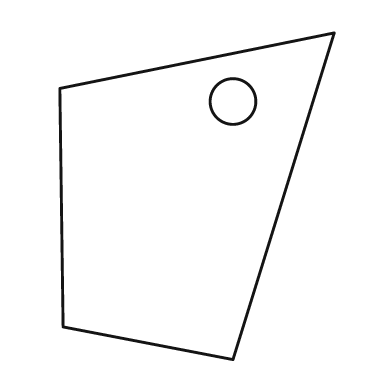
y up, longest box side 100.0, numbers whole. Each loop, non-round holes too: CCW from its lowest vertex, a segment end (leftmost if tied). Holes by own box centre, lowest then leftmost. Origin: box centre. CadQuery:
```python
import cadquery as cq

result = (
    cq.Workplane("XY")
    .moveTo(11.0, -50.0)
    .lineTo(42.0, 50.0)
    .lineTo(-42.0, 33.0)
    .lineTo(-41.0, -40.0)
    .close()
    .moveTo(11.0, 29.0)
    .circle(7.0)
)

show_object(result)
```